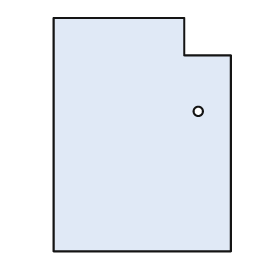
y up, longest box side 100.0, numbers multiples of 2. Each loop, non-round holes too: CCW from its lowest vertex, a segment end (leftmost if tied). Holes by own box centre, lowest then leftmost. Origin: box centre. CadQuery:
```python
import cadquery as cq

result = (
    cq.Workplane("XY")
    .moveTo(-38.0, -50.0)
    .lineTo(38.0, -50.0)
    .lineTo(38.0, 34.0)
    .lineTo(18.0, 34.0)
    .lineTo(18.0, 50.0)
    .lineTo(-38.0, 50.0)
    .close()
    .moveTo(24.0, 10.0)
    .circle(2.0)
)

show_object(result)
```